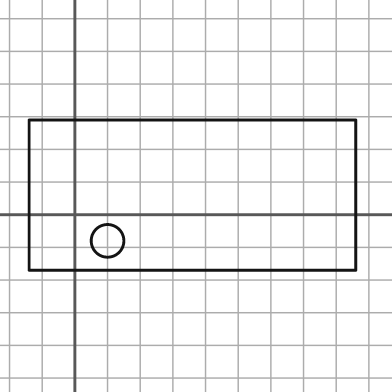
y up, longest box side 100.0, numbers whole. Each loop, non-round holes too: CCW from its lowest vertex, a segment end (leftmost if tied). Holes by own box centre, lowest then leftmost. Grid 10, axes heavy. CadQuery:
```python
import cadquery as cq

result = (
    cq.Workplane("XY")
    .moveTo(-14.0, -17.0)
    .lineTo(86.0, -17.0)
    .lineTo(86.0, 29.0)
    .lineTo(-14.0, 29.0)
    .close()
    .moveTo(10.0, -8.0)
    .circle(5.0)
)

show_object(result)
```